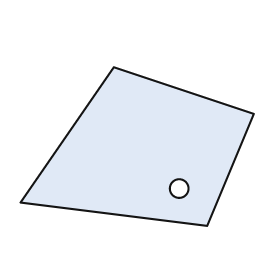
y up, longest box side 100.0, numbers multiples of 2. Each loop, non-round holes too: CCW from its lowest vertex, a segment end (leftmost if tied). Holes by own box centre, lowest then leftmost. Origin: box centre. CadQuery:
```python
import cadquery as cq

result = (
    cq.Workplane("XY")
    .moveTo(30.0, -34.0)
    .lineTo(50.0, 14.0)
    .lineTo(-10.0, 34.0)
    .lineTo(-50.0, -24.0)
    .close()
    .moveTo(18.0, -18.0)
    .circle(4.0)
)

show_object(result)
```